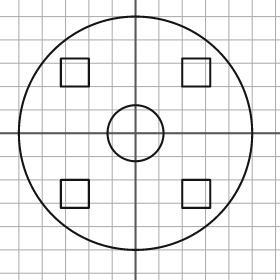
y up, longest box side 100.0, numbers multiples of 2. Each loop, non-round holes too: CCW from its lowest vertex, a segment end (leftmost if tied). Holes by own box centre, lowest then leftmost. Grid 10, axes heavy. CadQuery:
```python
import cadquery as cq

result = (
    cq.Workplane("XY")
    .moveTo(0.0, 0.0)
    .circle(50.0)
    .moveTo(-32.0, -32.0)
    .lineTo(-20.0, -32.0)
    .lineTo(-20.0, -20.0)
    .lineTo(-32.0, -20.0)
    .close()
    .moveTo(20.0, -32.0)
    .lineTo(32.0, -32.0)
    .lineTo(32.0, -20.0)
    .lineTo(20.0, -20.0)
    .close()
    .moveTo(0.0, 0.0)
    .circle(12.0)
    .moveTo(-32.0, 20.0)
    .lineTo(-20.0, 20.0)
    .lineTo(-20.0, 32.0)
    .lineTo(-32.0, 32.0)
    .close()
    .moveTo(20.0, 20.0)
    .lineTo(32.0, 20.0)
    .lineTo(32.0, 32.0)
    .lineTo(20.0, 32.0)
    .close()
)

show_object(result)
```